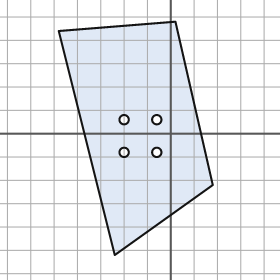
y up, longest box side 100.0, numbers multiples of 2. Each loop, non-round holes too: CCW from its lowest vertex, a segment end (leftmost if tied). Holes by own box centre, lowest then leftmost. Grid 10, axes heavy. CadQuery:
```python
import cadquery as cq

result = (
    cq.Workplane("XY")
    .moveTo(-24.0, -52.0)
    .lineTo(18.0, -22.0)
    .lineTo(2.0, 48.0)
    .lineTo(-48.0, 44.0)
    .close()
    .moveTo(-20.0, -8.0)
    .circle(2.0)
    .moveTo(-6.0, -8.0)
    .circle(2.0)
    .moveTo(-20.0, 6.0)
    .circle(2.0)
    .moveTo(-6.0, 6.0)
    .circle(2.0)
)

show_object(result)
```